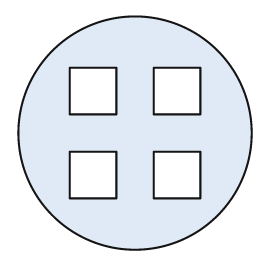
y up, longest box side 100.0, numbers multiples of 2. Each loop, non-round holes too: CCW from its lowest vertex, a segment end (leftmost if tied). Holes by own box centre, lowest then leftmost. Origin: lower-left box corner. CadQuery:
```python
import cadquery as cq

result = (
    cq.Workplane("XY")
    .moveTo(50.0, 50.0)
    .circle(50.0)
    .moveTo(22.0, 22.0)
    .lineTo(42.0, 22.0)
    .lineTo(42.0, 42.0)
    .lineTo(22.0, 42.0)
    .close()
    .moveTo(58.0, 22.0)
    .lineTo(78.0, 22.0)
    .lineTo(78.0, 42.0)
    .lineTo(58.0, 42.0)
    .close()
    .moveTo(22.0, 58.0)
    .lineTo(42.0, 58.0)
    .lineTo(42.0, 78.0)
    .lineTo(22.0, 78.0)
    .close()
    .moveTo(58.0, 58.0)
    .lineTo(78.0, 58.0)
    .lineTo(78.0, 78.0)
    .lineTo(58.0, 78.0)
    .close()
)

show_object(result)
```